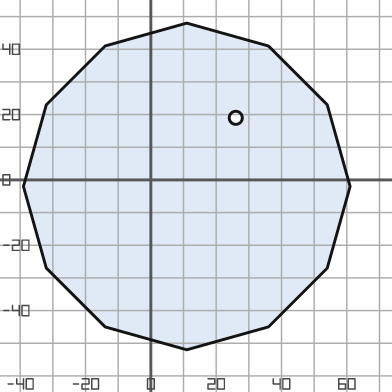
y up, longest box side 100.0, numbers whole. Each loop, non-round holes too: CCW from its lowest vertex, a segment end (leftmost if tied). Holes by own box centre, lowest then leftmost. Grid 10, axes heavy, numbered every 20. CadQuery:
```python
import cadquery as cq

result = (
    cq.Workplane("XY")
    .moveTo(11.0, -52.0)
    .lineTo(36.0, -45.0)
    .lineTo(54.0, -27.0)
    .lineTo(61.0, -2.0)
    .lineTo(54.0, 23.0)
    .lineTo(36.0, 41.0)
    .lineTo(11.0, 48.0)
    .lineTo(-14.0, 41.0)
    .lineTo(-32.0, 23.0)
    .lineTo(-39.0, -2.0)
    .lineTo(-32.0, -27.0)
    .lineTo(-14.0, -45.0)
    .close()
    .moveTo(26.0, 19.0)
    .circle(2.0)
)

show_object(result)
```